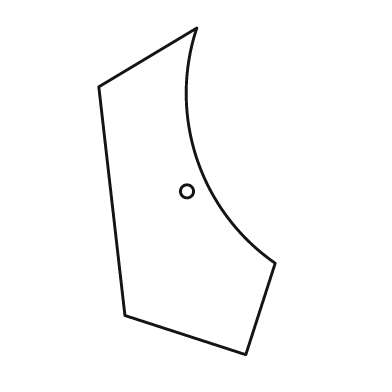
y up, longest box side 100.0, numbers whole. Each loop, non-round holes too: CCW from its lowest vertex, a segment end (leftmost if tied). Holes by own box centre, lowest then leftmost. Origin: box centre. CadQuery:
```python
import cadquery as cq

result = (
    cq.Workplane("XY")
    .moveTo(18.0, -50.0)
    .lineTo(27.0, -22.0)
    .threePointArc((3.0, 10.0), (3.0, 50.0))
    .lineTo(-27.0, 32.0)
    .lineTo(-19.0, -38.0)
    .close()
    .moveTo(0.0, 0.0)
    .circle(2.0)
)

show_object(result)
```